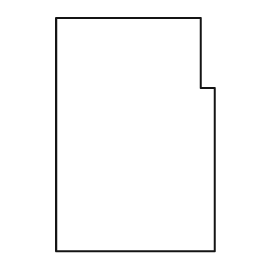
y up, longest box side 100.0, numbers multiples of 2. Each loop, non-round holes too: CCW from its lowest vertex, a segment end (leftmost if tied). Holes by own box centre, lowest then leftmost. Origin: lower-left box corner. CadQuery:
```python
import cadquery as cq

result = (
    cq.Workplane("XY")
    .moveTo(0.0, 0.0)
    .lineTo(68.0, 0.0)
    .lineTo(68.0, 70.0)
    .lineTo(62.0, 70.0)
    .lineTo(62.0, 100.0)
    .lineTo(0.0, 100.0)
    .close()
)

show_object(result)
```